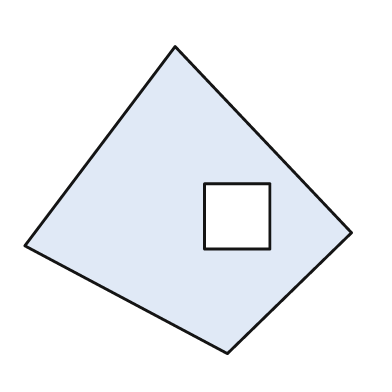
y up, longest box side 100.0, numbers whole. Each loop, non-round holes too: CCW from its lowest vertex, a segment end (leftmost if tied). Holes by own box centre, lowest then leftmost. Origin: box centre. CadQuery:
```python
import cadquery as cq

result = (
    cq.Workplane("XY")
    .moveTo(12.0, -47.0)
    .lineTo(50.0, -10.0)
    .lineTo(-4.0, 47.0)
    .lineTo(-50.0, -14.0)
    .close()
    .moveTo(5.0, -15.0)
    .lineTo(25.0, -15.0)
    .lineTo(25.0, 5.0)
    .lineTo(5.0, 5.0)
    .close()
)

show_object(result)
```